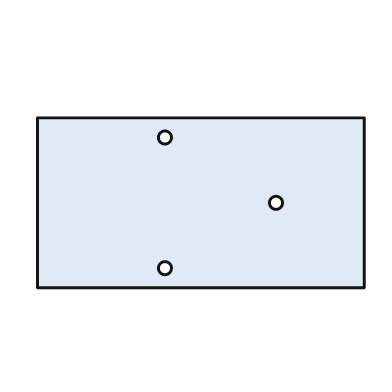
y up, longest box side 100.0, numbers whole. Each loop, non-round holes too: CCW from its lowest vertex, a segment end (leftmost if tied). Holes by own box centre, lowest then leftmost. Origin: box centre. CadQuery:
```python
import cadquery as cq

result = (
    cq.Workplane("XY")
    .moveTo(-50.0, -26.0)
    .lineTo(50.0, -26.0)
    .lineTo(50.0, 26.0)
    .lineTo(-50.0, 26.0)
    .close()
    .moveTo(-11.0, -20.0)
    .circle(2.0)
    .moveTo(23.0, 0.0)
    .circle(2.0)
    .moveTo(-11.0, 20.0)
    .circle(2.0)
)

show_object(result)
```